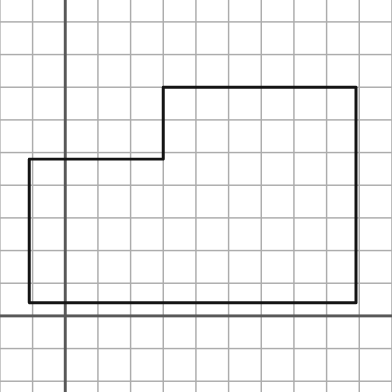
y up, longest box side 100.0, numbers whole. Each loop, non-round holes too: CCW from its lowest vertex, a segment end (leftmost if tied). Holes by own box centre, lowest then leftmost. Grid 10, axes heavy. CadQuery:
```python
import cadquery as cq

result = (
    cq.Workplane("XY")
    .moveTo(-11.0, 4.0)
    .lineTo(89.0, 4.0)
    .lineTo(89.0, 70.0)
    .lineTo(30.0, 70.0)
    .lineTo(30.0, 48.0)
    .lineTo(-11.0, 48.0)
    .close()
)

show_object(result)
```